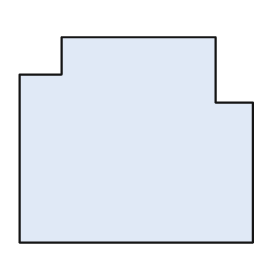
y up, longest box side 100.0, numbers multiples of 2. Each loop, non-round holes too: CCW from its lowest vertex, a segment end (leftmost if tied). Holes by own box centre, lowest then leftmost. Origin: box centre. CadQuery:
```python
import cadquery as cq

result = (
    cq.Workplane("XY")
    .moveTo(-50.0, -44.0)
    .lineTo(50.0, -44.0)
    .lineTo(50.0, 16.0)
    .lineTo(34.0, 16.0)
    .lineTo(34.0, 44.0)
    .lineTo(-32.0, 44.0)
    .lineTo(-32.0, 28.0)
    .lineTo(-50.0, 28.0)
    .close()
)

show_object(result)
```